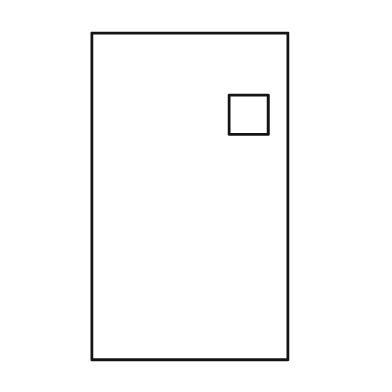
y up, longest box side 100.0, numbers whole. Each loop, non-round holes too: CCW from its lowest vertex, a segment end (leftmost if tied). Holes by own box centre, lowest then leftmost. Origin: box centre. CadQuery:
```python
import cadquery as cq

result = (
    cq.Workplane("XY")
    .moveTo(-30.0, -50.0)
    .lineTo(30.0, -50.0)
    .lineTo(30.0, 50.0)
    .lineTo(-30.0, 50.0)
    .close()
    .moveTo(12.0, 19.0)
    .lineTo(24.0, 19.0)
    .lineTo(24.0, 31.0)
    .lineTo(12.0, 31.0)
    .close()
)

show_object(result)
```